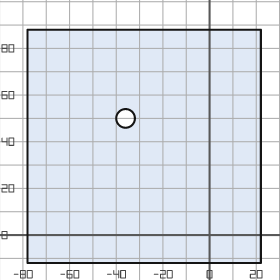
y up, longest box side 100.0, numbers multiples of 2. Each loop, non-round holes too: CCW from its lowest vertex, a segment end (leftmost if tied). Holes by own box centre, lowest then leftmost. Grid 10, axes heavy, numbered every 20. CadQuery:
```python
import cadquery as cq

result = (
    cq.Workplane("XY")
    .moveTo(-78.0, -12.0)
    .lineTo(22.0, -12.0)
    .lineTo(22.0, 88.0)
    .lineTo(-78.0, 88.0)
    .close()
    .moveTo(-36.0, 50.0)
    .circle(4.0)
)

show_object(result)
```